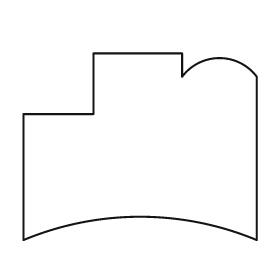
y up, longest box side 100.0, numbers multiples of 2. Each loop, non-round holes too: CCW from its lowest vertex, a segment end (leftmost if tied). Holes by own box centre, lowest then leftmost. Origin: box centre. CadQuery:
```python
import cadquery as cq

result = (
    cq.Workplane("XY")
    .moveTo(-50.0, -40.0)
    .threePointArc((0.0, -30.0), (50.0, -40.0))
    .lineTo(50.0, 30.0)
    .threePointArc((34.0, 38.0), (18.0, 30.0))
    .lineTo(18.0, 40.0)
    .lineTo(-20.0, 40.0)
    .lineTo(-20.0, 14.0)
    .lineTo(-50.0, 14.0)
    .close()
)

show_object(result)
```